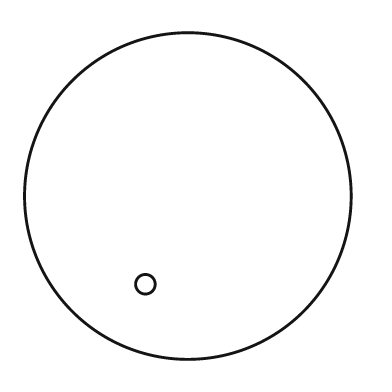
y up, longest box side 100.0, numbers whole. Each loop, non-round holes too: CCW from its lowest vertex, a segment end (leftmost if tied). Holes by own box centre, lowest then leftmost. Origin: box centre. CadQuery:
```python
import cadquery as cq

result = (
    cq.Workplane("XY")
    .moveTo(0.0, 0.0)
    .circle(50.0)
    .moveTo(-13.0, -27.0)
    .circle(3.0)
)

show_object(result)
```